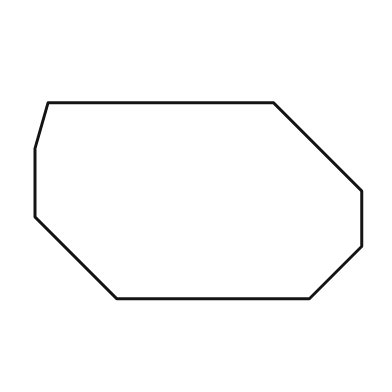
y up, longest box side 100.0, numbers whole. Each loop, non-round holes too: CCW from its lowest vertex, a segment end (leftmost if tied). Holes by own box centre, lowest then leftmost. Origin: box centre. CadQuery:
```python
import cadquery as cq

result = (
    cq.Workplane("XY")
    .moveTo(-25.0, -30.0)
    .lineTo(34.0, -30.0)
    .lineTo(50.0, -14.0)
    .lineTo(50.0, 3.0)
    .lineTo(23.0, 30.0)
    .lineTo(-46.0, 30.0)
    .lineTo(-50.0, 16.0)
    .lineTo(-50.0, -5.0)
    .close()
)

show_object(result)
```